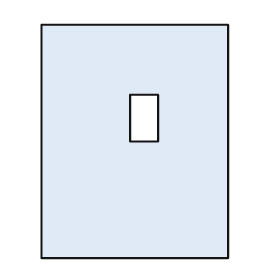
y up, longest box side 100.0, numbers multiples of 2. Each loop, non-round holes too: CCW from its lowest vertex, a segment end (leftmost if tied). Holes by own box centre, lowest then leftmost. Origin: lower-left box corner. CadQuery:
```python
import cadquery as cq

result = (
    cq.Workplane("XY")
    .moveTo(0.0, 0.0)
    .lineTo(80.0, 0.0)
    .lineTo(80.0, 100.0)
    .lineTo(0.0, 100.0)
    .close()
    .moveTo(38.0, 50.0)
    .lineTo(50.0, 50.0)
    .lineTo(50.0, 70.0)
    .lineTo(38.0, 70.0)
    .close()
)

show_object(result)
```